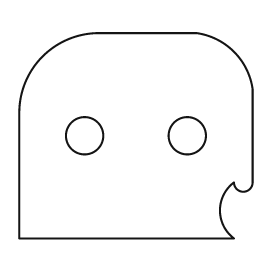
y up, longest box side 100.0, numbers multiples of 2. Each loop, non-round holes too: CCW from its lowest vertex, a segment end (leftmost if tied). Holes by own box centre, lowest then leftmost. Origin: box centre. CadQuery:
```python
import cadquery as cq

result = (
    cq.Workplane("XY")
    .moveTo(-50.0, -44.0)
    .lineTo(42.0, -44.0)
    .threePointArc((36.0, -32.0), (42.0, -20.0))
    .threePointArc((46.0, -24.0), (50.0, -20.0))
    .lineTo(50.0, 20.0)
    .threePointArc((42.0, 36.0), (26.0, 44.0))
    .lineTo(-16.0, 44.0)
    .threePointArc((-40.0, 34.0), (-50.0, 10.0))
    .close()
    .moveTo(-22.0, 0.0)
    .circle(8.0)
    .moveTo(22.0, 0.0)
    .circle(8.0)
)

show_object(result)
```